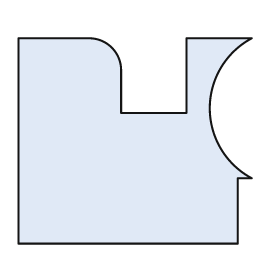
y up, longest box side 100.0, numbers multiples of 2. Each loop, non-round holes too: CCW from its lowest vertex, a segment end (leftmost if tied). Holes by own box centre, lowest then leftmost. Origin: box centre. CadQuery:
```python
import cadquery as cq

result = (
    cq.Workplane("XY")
    .moveTo(-50.0, -44.0)
    .lineTo(44.0, -44.0)
    .lineTo(44.0, -16.0)
    .lineTo(50.0, -16.0)
    .threePointArc((32.0, 14.0), (50.0, 44.0))
    .lineTo(22.0, 44.0)
    .lineTo(22.0, 12.0)
    .lineTo(-6.0, 12.0)
    .lineTo(-6.0, 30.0)
    .threePointArc((-10.0, 40.0), (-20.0, 44.0))
    .lineTo(-50.0, 44.0)
    .close()
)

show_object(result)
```